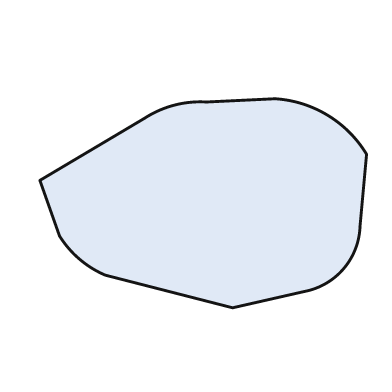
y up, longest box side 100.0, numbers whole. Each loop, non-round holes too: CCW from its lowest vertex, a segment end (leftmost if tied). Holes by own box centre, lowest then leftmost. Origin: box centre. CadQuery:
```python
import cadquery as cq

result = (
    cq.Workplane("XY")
    .moveTo(9.0, -32.0)
    .lineTo(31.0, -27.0)
    .threePointArc((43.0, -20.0), (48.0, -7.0))
    .lineTo(50.0, 15.0)
    .threePointArc((38.0, 27.0), (22.0, 32.0))
    .lineTo(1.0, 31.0)
    .threePointArc((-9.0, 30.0), (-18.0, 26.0))
    .lineTo(-50.0, 7.0)
    .lineTo(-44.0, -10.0)
    .threePointArc((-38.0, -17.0), (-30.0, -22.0))
    .close()
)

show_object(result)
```